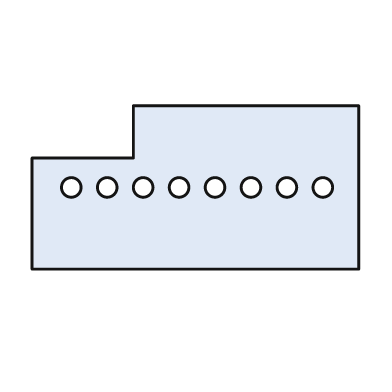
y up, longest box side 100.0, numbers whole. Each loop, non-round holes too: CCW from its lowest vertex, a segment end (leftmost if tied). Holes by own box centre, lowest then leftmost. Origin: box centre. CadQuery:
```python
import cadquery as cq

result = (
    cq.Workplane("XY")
    .moveTo(-50.0, -25.0)
    .lineTo(50.0, -25.0)
    .lineTo(50.0, 25.0)
    .lineTo(-19.0, 25.0)
    .lineTo(-19.0, 9.0)
    .lineTo(-50.0, 9.0)
    .close()
    .moveTo(-38.0, 0.0)
    .circle(3.0)
    .moveTo(-27.0, 0.0)
    .circle(3.0)
    .moveTo(-16.0, 0.0)
    .circle(3.0)
    .moveTo(-5.0, 0.0)
    .circle(3.0)
    .moveTo(6.0, 0.0)
    .circle(3.0)
    .moveTo(17.0, 0.0)
    .circle(3.0)
    .moveTo(28.0, 0.0)
    .circle(3.0)
    .moveTo(39.0, 0.0)
    .circle(3.0)
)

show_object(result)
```